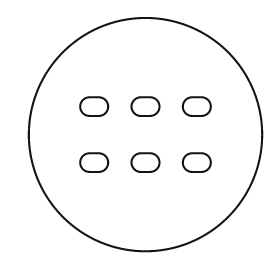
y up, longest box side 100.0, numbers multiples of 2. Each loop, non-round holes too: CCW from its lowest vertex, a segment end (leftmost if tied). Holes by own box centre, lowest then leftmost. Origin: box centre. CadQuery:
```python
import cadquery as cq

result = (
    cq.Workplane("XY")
    .moveTo(0.0, 0.0)
    .circle(50.0)
    .moveTo(-24.0, -16.0)
    .lineTo(-20.0, -16.0)
    .threePointArc((-16.0, -12.0), (-20.0, -8.0))
    .lineTo(-24.0, -8.0)
    .threePointArc((-28.0, -12.0), (-24.0, -16.0))
    .close()
    .moveTo(-2.0, -16.0)
    .lineTo(2.0, -16.0)
    .threePointArc((6.0, -12.0), (2.0, -8.0))
    .lineTo(-2.0, -8.0)
    .threePointArc((-6.0, -12.0), (-2.0, -16.0))
    .close()
    .moveTo(20.0, -16.0)
    .lineTo(24.0, -16.0)
    .threePointArc((28.0, -12.0), (24.0, -8.0))
    .lineTo(20.0, -8.0)
    .threePointArc((16.0, -12.0), (20.0, -16.0))
    .close()
    .moveTo(-24.0, 8.0)
    .lineTo(-20.0, 8.0)
    .threePointArc((-16.0, 12.0), (-20.0, 16.0))
    .lineTo(-24.0, 16.0)
    .threePointArc((-28.0, 12.0), (-24.0, 8.0))
    .close()
    .moveTo(-2.0, 8.0)
    .lineTo(2.0, 8.0)
    .threePointArc((6.0, 12.0), (2.0, 16.0))
    .lineTo(-2.0, 16.0)
    .threePointArc((-6.0, 12.0), (-2.0, 8.0))
    .close()
    .moveTo(20.0, 8.0)
    .lineTo(24.0, 8.0)
    .threePointArc((28.0, 12.0), (24.0, 16.0))
    .lineTo(20.0, 16.0)
    .threePointArc((16.0, 12.0), (20.0, 8.0))
    .close()
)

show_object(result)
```